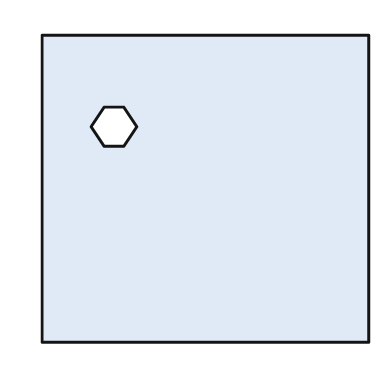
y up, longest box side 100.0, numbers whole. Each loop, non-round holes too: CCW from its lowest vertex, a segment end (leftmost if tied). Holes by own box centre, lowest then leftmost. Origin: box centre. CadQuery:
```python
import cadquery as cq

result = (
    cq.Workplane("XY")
    .moveTo(-50.0, -47.0)
    .lineTo(50.0, -47.0)
    .lineTo(50.0, 47.0)
    .lineTo(-50.0, 47.0)
    .close()
    .moveTo(-31.0, 13.0)
    .lineTo(-25.0, 13.0)
    .lineTo(-21.0, 19.0)
    .lineTo(-25.0, 25.0)
    .lineTo(-31.0, 25.0)
    .lineTo(-35.0, 19.0)
    .close()
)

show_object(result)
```